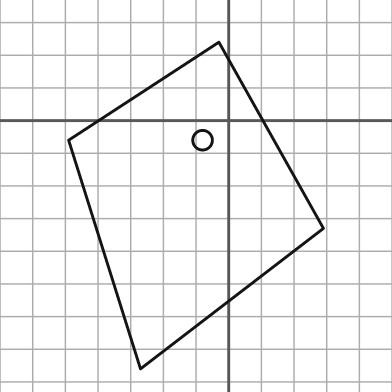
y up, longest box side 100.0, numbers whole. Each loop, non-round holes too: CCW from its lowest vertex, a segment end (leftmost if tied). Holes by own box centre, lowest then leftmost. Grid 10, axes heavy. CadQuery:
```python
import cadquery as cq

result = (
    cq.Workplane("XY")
    .moveTo(-27.0, -76.0)
    .lineTo(29.0, -33.0)
    .lineTo(-3.0, 24.0)
    .lineTo(-49.0, -6.0)
    .close()
    .moveTo(-8.0, -6.0)
    .circle(3.0)
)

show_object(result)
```